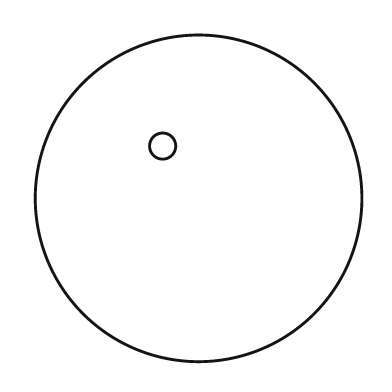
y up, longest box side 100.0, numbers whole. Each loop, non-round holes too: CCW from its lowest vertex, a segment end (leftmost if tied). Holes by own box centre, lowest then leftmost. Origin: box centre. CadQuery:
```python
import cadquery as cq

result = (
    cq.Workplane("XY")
    .moveTo(0.0, 0.0)
    .circle(50.0)
    .moveTo(-11.0, 16.0)
    .circle(4.0)
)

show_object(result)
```